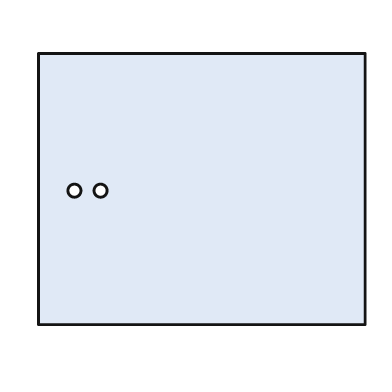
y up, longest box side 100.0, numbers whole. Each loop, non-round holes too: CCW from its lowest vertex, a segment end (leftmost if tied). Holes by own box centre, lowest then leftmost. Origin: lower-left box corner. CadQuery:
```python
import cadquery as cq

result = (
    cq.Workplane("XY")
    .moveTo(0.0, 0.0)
    .lineTo(100.0, 0.0)
    .lineTo(100.0, 83.0)
    .lineTo(0.0, 83.0)
    .close()
    .moveTo(11.0, 41.0)
    .circle(2.0)
    .moveTo(19.0, 41.0)
    .circle(2.0)
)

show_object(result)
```